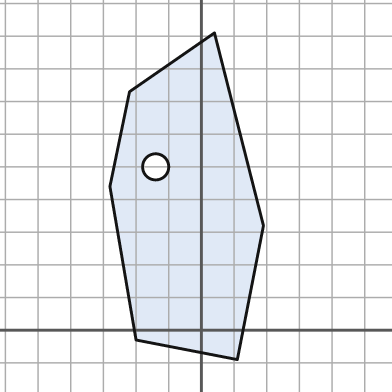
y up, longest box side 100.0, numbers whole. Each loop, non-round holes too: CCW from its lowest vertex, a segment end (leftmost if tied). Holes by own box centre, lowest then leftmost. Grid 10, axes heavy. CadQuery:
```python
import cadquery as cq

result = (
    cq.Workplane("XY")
    .moveTo(11.0, -9.0)
    .lineTo(19.0, 32.0)
    .lineTo(4.0, 91.0)
    .lineTo(-22.0, 73.0)
    .lineTo(-28.0, 44.0)
    .lineTo(-20.0, -3.0)
    .close()
    .moveTo(-14.0, 50.0)
    .circle(4.0)
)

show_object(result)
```